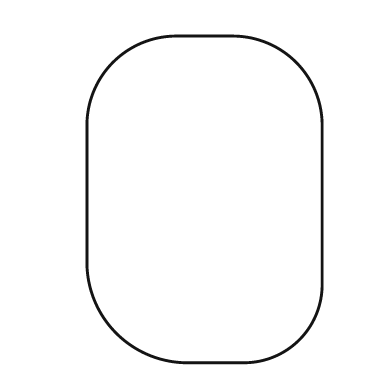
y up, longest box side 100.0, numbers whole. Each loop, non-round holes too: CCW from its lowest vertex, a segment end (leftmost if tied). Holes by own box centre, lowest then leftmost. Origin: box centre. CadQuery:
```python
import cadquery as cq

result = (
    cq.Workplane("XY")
    .moveTo(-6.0, -50.0)
    .lineTo(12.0, -50.0)
    .threePointArc((29.0, -43.0), (36.0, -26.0))
    .lineTo(36.0, 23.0)
    .threePointArc((28.0, 42.0), (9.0, 50.0))
    .lineTo(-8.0, 50.0)
    .threePointArc((-28.0, 42.0), (-36.0, 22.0))
    .lineTo(-36.0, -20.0)
    .threePointArc((-27.0, -41.0), (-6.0, -50.0))
    .close()
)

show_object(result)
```